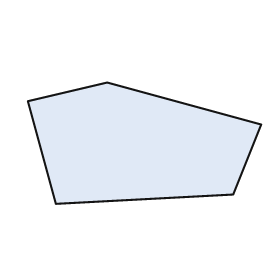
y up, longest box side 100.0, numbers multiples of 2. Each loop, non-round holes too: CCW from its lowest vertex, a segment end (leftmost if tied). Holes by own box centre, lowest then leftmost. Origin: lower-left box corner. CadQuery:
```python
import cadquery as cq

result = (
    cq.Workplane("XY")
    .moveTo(12.0, 0.0)
    .lineTo(88.0, 4.0)
    .lineTo(100.0, 34.0)
    .lineTo(34.0, 52.0)
    .lineTo(0.0, 44.0)
    .close()
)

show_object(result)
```